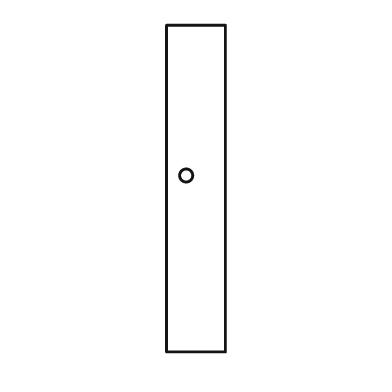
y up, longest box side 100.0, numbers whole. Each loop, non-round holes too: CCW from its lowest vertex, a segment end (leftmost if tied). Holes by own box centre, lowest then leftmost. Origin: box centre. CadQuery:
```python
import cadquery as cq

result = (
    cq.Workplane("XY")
    .moveTo(-9.0, -50.0)
    .lineTo(9.0, -50.0)
    .lineTo(9.0, 50.0)
    .lineTo(-9.0, 50.0)
    .close()
    .moveTo(-3.0, 4.0)
    .circle(2.0)
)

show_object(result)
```